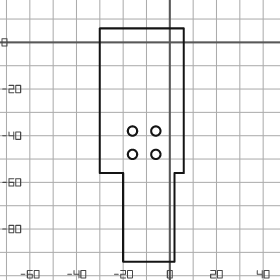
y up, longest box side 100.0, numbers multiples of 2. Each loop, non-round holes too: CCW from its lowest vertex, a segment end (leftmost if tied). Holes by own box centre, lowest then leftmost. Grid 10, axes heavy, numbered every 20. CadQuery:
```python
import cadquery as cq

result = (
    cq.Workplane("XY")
    .moveTo(-20.0, -94.0)
    .lineTo(2.0, -94.0)
    .lineTo(2.0, -56.0)
    .lineTo(6.0, -56.0)
    .lineTo(6.0, 6.0)
    .lineTo(-30.0, 6.0)
    .lineTo(-30.0, -56.0)
    .lineTo(-20.0, -56.0)
    .close()
    .moveTo(-16.0, -48.0)
    .circle(2.0)
    .moveTo(-6.0, -48.0)
    .circle(2.0)
    .moveTo(-16.0, -38.0)
    .circle(2.0)
    .moveTo(-6.0, -38.0)
    .circle(2.0)
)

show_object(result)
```